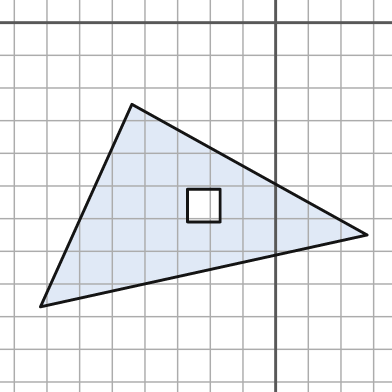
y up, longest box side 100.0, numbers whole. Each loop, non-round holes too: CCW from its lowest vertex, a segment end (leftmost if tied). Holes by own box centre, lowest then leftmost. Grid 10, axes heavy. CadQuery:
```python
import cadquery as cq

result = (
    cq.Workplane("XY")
    .moveTo(-72.0, -87.0)
    .lineTo(28.0, -65.0)
    .lineTo(-44.0, -25.0)
    .close()
    .moveTo(-27.0, -61.0)
    .lineTo(-17.0, -61.0)
    .lineTo(-17.0, -51.0)
    .lineTo(-27.0, -51.0)
    .close()
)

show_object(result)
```